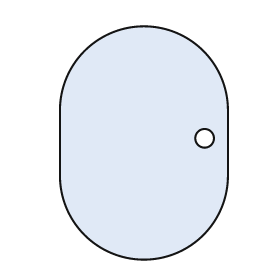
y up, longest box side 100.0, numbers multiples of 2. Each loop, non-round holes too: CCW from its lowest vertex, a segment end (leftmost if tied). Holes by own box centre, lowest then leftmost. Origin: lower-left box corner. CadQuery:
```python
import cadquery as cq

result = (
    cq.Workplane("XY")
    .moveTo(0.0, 36.0)
    .threePointArc((36.0, 0.0), (72.0, 36.0))
    .lineTo(72.0, 64.0)
    .threePointArc((36.0, 100.0), (0.0, 64.0))
    .close()
    .moveTo(62.0, 52.0)
    .circle(4.0)
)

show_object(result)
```